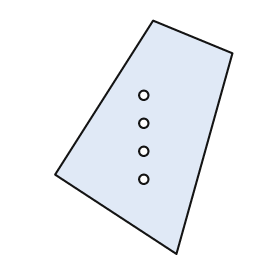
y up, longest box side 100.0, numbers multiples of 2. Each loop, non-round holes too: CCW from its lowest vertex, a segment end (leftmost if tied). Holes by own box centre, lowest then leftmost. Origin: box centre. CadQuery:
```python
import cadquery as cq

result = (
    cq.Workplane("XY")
    .moveTo(14.0, -50.0)
    .lineTo(38.0, 36.0)
    .lineTo(4.0, 50.0)
    .lineTo(-38.0, -16.0)
    .close()
    .moveTo(0.0, -18.0)
    .circle(2.0)
    .moveTo(0.0, -6.0)
    .circle(2.0)
    .moveTo(0.0, 6.0)
    .circle(2.0)
    .moveTo(0.0, 18.0)
    .circle(2.0)
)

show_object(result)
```